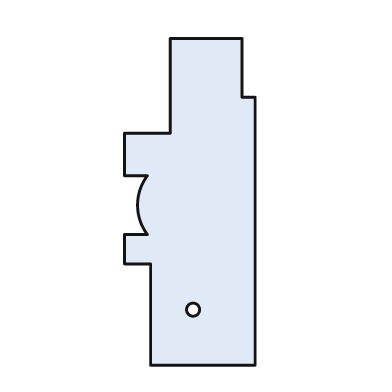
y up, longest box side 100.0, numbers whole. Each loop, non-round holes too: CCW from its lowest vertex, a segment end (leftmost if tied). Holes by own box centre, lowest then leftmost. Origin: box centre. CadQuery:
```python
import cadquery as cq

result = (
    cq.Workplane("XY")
    .moveTo(-12.0, -50.0)
    .lineTo(20.0, -50.0)
    .lineTo(20.0, 32.0)
    .lineTo(16.0, 32.0)
    .lineTo(16.0, 50.0)
    .lineTo(-6.0, 50.0)
    .lineTo(-6.0, 21.0)
    .lineTo(-20.0, 21.0)
    .lineTo(-20.0, 8.0)
    .lineTo(-13.0, 8.0)
    .threePointArc((-16.0, -1.0), (-13.0, -10.0))
    .lineTo(-20.0, -10.0)
    .lineTo(-20.0, -19.0)
    .lineTo(-12.0, -19.0)
    .close()
    .moveTo(1.0, -33.0)
    .circle(2.0)
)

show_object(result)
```